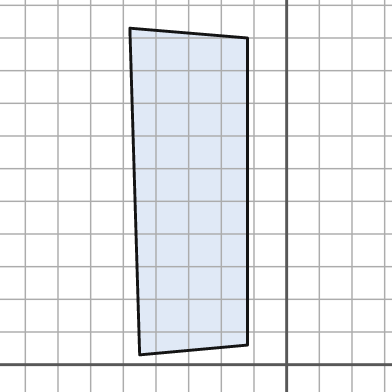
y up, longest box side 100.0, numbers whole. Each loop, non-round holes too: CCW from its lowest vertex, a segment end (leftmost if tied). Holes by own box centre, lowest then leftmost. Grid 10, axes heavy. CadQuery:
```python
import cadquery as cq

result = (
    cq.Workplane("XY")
    .moveTo(-45.0, 3.0)
    .lineTo(-12.0, 6.0)
    .lineTo(-12.0, 100.0)
    .lineTo(-48.0, 103.0)
    .close()
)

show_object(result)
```